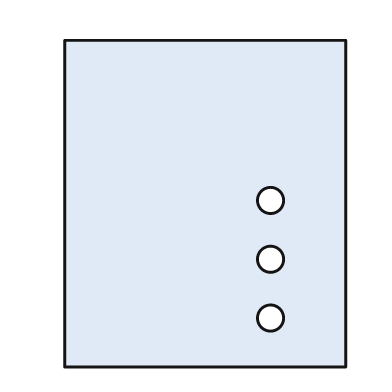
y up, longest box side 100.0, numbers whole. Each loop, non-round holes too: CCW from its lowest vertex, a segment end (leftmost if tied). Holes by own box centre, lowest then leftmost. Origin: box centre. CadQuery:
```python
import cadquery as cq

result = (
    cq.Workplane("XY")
    .moveTo(-43.0, -50.0)
    .lineTo(43.0, -50.0)
    .lineTo(43.0, 50.0)
    .lineTo(-43.0, 50.0)
    .close()
    .moveTo(20.0, -35.0)
    .circle(4.0)
    .moveTo(20.0, -17.0)
    .circle(4.0)
    .moveTo(20.0, 1.0)
    .circle(4.0)
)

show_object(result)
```